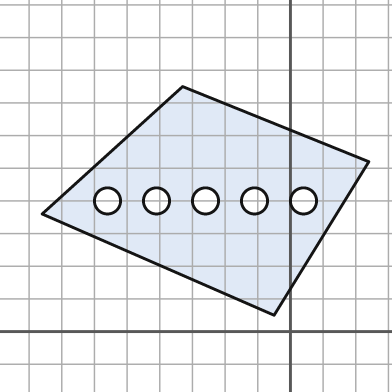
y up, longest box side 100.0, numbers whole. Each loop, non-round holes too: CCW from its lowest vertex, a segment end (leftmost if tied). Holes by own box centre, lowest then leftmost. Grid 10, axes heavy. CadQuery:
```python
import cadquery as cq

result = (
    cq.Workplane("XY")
    .moveTo(-5.0, 5.0)
    .lineTo(24.0, 52.0)
    .lineTo(-33.0, 75.0)
    .lineTo(-76.0, 36.0)
    .close()
    .moveTo(-56.0, 40.0)
    .circle(4.0)
    .moveTo(-41.0, 40.0)
    .circle(4.0)
    .moveTo(-26.0, 40.0)
    .circle(4.0)
    .moveTo(-11.0, 40.0)
    .circle(4.0)
    .moveTo(4.0, 40.0)
    .circle(4.0)
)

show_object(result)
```